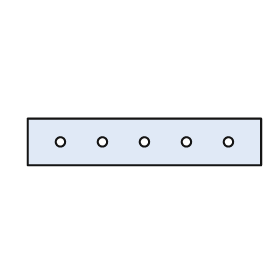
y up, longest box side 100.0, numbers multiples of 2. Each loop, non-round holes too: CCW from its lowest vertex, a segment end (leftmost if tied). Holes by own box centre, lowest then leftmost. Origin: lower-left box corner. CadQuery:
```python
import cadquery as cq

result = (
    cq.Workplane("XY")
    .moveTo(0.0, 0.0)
    .lineTo(100.0, 0.0)
    .lineTo(100.0, 20.0)
    .lineTo(0.0, 20.0)
    .close()
    .moveTo(14.0, 10.0)
    .circle(2.0)
    .moveTo(32.0, 10.0)
    .circle(2.0)
    .moveTo(50.0, 10.0)
    .circle(2.0)
    .moveTo(68.0, 10.0)
    .circle(2.0)
    .moveTo(86.0, 10.0)
    .circle(2.0)
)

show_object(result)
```